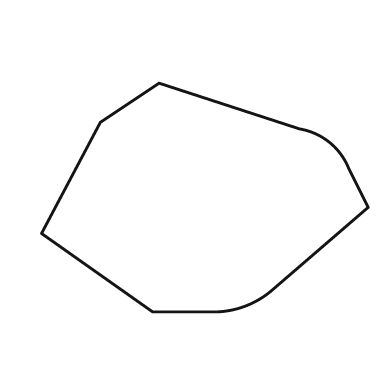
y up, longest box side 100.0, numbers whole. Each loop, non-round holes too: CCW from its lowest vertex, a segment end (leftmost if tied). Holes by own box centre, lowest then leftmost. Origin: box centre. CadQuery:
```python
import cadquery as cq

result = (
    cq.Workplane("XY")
    .moveTo(-16.0, -35.0)
    .lineTo(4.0, -35.0)
    .threePointArc((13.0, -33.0), (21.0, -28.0))
    .lineTo(50.0, -3.0)
    .lineTo(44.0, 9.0)
    .threePointArc((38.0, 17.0), (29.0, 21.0))
    .lineTo(-14.0, 35.0)
    .lineTo(-32.0, 23.0)
    .lineTo(-50.0, -11.0)
    .close()
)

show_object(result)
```